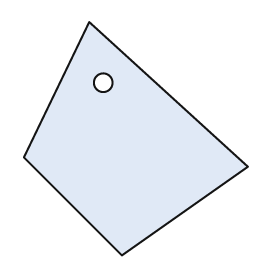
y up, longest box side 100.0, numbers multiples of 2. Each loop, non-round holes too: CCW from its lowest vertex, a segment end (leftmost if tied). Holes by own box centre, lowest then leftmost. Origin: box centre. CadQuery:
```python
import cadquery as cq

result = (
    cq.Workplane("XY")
    .moveTo(-6.0, -50.0)
    .lineTo(48.0, -12.0)
    .lineTo(-20.0, 50.0)
    .lineTo(-48.0, -8.0)
    .close()
    .moveTo(-14.0, 24.0)
    .circle(4.0)
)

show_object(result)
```